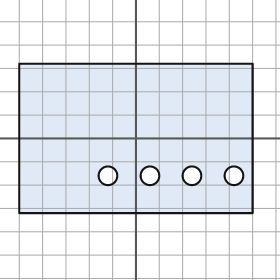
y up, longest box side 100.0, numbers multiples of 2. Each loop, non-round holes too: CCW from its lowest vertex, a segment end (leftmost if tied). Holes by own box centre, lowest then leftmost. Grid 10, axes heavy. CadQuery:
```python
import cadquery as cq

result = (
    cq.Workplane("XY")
    .moveTo(-50.0, -32.0)
    .lineTo(50.0, -32.0)
    .lineTo(50.0, 32.0)
    .lineTo(-50.0, 32.0)
    .close()
    .moveTo(-12.0, -16.0)
    .circle(4.0)
    .moveTo(6.0, -16.0)
    .circle(4.0)
    .moveTo(24.0, -16.0)
    .circle(4.0)
    .moveTo(42.0, -16.0)
    .circle(4.0)
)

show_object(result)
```